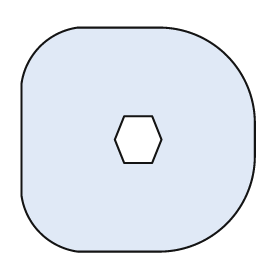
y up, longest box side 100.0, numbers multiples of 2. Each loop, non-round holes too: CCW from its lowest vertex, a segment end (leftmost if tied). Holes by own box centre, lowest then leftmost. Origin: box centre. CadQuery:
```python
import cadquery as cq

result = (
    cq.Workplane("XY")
    .moveTo(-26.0, -48.0)
    .lineTo(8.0, -48.0)
    .threePointArc((38.0, -36.0), (50.0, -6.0))
    .lineTo(50.0, 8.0)
    .threePointArc((38.0, 36.0), (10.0, 48.0))
    .lineTo(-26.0, 48.0)
    .threePointArc((-42.0, 40.0), (-50.0, 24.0))
    .lineTo(-50.0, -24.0)
    .threePointArc((-42.0, -40.0), (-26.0, -48.0))
    .close()
    .moveTo(-6.0, -10.0)
    .lineTo(6.0, -10.0)
    .lineTo(10.0, 0.0)
    .lineTo(6.0, 10.0)
    .lineTo(-6.0, 10.0)
    .lineTo(-10.0, 0.0)
    .close()
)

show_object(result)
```